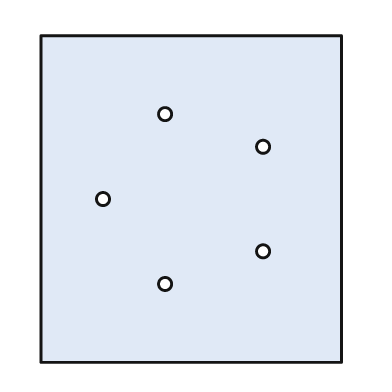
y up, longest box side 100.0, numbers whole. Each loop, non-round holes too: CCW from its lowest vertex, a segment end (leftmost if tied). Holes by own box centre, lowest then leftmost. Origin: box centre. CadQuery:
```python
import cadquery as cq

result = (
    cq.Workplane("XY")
    .moveTo(-46.0, -50.0)
    .lineTo(46.0, -50.0)
    .lineTo(46.0, 50.0)
    .lineTo(-46.0, 50.0)
    .close()
    .moveTo(-8.0, -26.0)
    .circle(2.0)
    .moveTo(22.0, -16.0)
    .circle(2.0)
    .moveTo(-27.0, 0.0)
    .circle(2.0)
    .moveTo(22.0, 16.0)
    .circle(2.0)
    .moveTo(-8.0, 26.0)
    .circle(2.0)
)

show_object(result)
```